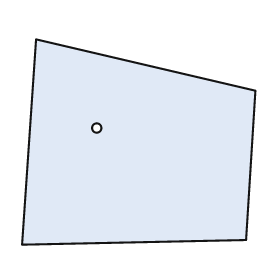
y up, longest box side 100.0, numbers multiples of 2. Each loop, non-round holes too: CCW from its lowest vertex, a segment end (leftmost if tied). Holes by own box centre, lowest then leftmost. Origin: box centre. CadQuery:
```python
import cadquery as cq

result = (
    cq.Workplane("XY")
    .moveTo(-50.0, -44.0)
    .lineTo(46.0, -42.0)
    .lineTo(50.0, 22.0)
    .lineTo(-44.0, 44.0)
    .close()
    .moveTo(-18.0, 6.0)
    .circle(2.0)
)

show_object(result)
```